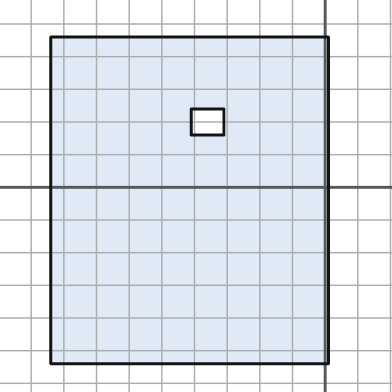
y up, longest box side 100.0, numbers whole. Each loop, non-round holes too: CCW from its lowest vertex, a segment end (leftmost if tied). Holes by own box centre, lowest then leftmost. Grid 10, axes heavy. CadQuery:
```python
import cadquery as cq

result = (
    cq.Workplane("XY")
    .moveTo(-84.0, -54.0)
    .lineTo(1.0, -54.0)
    .lineTo(1.0, 46.0)
    .lineTo(-84.0, 46.0)
    .close()
    .moveTo(-41.0, 16.0)
    .lineTo(-31.0, 16.0)
    .lineTo(-31.0, 24.0)
    .lineTo(-41.0, 24.0)
    .close()
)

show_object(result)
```